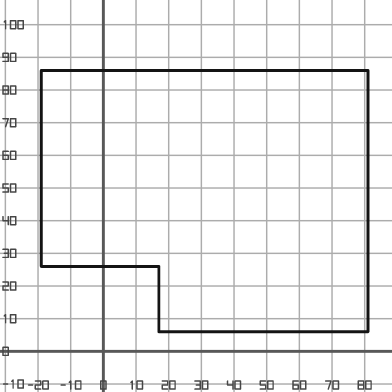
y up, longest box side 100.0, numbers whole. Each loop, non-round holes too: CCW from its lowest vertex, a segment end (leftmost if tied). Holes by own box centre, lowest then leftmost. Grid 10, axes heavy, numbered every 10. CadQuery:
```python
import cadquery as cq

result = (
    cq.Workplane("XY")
    .moveTo(17.0, 6.0)
    .lineTo(81.0, 6.0)
    .lineTo(81.0, 86.0)
    .lineTo(-19.0, 86.0)
    .lineTo(-19.0, 26.0)
    .lineTo(17.0, 26.0)
    .close()
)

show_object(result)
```